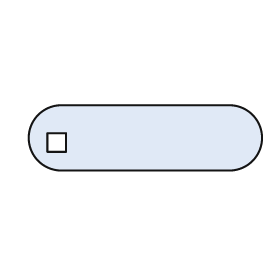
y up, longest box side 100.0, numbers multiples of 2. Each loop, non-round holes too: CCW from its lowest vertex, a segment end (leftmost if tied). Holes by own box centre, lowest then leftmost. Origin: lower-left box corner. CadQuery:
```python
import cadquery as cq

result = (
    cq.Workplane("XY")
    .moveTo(14.0, 0.0)
    .lineTo(86.0, 0.0)
    .threePointArc((100.0, 14.0), (86.0, 28.0))
    .lineTo(14.0, 28.0)
    .threePointArc((0.0, 14.0), (14.0, 0.0))
    .close()
    .moveTo(8.0, 8.0)
    .lineTo(16.0, 8.0)
    .lineTo(16.0, 16.0)
    .lineTo(8.0, 16.0)
    .close()
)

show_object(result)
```